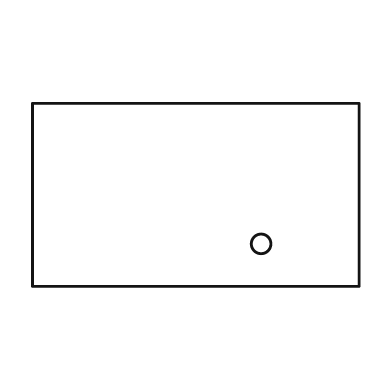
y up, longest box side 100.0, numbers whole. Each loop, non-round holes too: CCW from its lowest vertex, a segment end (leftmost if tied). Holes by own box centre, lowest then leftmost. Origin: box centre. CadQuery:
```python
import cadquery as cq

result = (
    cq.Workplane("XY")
    .moveTo(-50.0, -28.0)
    .lineTo(50.0, -28.0)
    .lineTo(50.0, 28.0)
    .lineTo(-50.0, 28.0)
    .close()
    .moveTo(20.0, -15.0)
    .circle(3.0)
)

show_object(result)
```